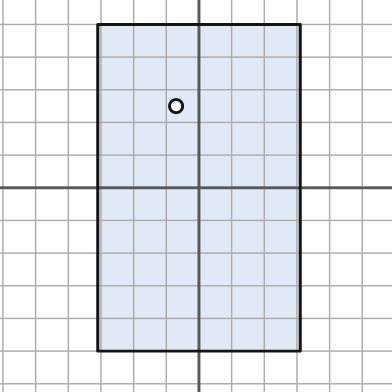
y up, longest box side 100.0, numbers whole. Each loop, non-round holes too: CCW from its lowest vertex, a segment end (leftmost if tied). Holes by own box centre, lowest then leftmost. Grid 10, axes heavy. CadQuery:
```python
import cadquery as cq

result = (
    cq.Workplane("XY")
    .moveTo(-31.0, -50.0)
    .lineTo(31.0, -50.0)
    .lineTo(31.0, 50.0)
    .lineTo(-31.0, 50.0)
    .close()
    .moveTo(-7.0, 25.0)
    .circle(2.0)
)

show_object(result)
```